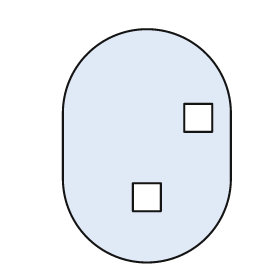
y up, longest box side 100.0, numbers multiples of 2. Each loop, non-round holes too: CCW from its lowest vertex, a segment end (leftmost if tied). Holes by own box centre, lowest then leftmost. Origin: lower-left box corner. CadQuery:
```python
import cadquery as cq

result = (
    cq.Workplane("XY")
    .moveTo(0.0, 36.0)
    .threePointArc((36.0, 0.0), (72.0, 36.0))
    .lineTo(72.0, 64.0)
    .threePointArc((36.0, 100.0), (0.0, 64.0))
    .close()
    .moveTo(30.0, 22.0)
    .lineTo(42.0, 22.0)
    .lineTo(42.0, 34.0)
    .lineTo(30.0, 34.0)
    .close()
    .moveTo(52.0, 56.0)
    .lineTo(64.0, 56.0)
    .lineTo(64.0, 68.0)
    .lineTo(52.0, 68.0)
    .close()
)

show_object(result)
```